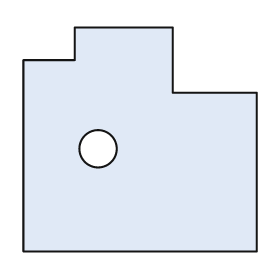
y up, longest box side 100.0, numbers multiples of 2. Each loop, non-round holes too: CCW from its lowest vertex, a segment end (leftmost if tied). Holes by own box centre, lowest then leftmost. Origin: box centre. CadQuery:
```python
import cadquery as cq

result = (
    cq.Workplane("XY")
    .moveTo(-50.0, -48.0)
    .lineTo(50.0, -48.0)
    .lineTo(50.0, 20.0)
    .lineTo(14.0, 20.0)
    .lineTo(14.0, 48.0)
    .lineTo(-28.0, 48.0)
    .lineTo(-28.0, 34.0)
    .lineTo(-50.0, 34.0)
    .close()
    .moveTo(-18.0, -4.0)
    .circle(8.0)
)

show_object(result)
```